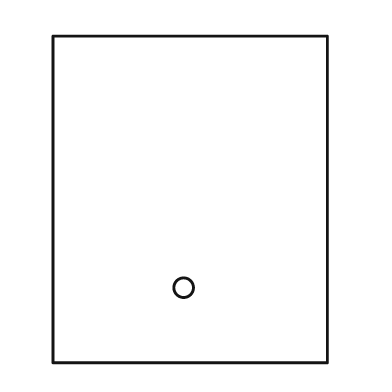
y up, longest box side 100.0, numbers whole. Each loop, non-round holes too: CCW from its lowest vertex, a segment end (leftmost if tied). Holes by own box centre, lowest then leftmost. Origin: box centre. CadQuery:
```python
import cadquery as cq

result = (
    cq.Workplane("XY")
    .moveTo(-42.0, -50.0)
    .lineTo(42.0, -50.0)
    .lineTo(42.0, 50.0)
    .lineTo(-42.0, 50.0)
    .close()
    .moveTo(-2.0, -27.0)
    .circle(3.0)
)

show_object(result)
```